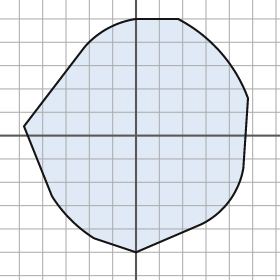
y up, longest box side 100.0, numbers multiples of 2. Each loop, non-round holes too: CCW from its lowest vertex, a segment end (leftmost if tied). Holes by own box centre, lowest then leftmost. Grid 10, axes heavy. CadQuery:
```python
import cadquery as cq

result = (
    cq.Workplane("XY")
    .moveTo(0.0, -50.0)
    .lineTo(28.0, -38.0)
    .threePointArc((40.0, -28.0), (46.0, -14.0))
    .lineTo(48.0, 16.0)
    .threePointArc((36.0, 36.0), (18.0, 50.0))
    .lineTo(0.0, 50.0)
    .threePointArc((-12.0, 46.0), (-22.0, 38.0))
    .lineTo(-48.0, 4.0)
    .lineTo(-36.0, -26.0)
    .threePointArc((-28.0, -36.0), (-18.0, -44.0))
    .close()
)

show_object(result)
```